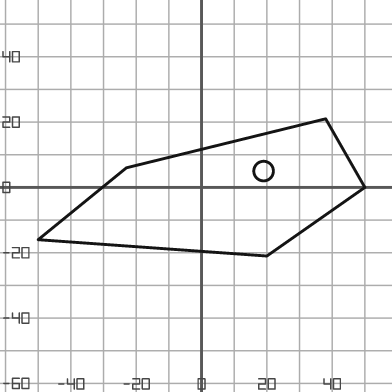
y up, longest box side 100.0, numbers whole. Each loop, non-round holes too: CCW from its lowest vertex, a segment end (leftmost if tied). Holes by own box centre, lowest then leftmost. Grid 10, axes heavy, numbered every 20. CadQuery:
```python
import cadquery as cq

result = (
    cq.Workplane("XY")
    .moveTo(20.0, -21.0)
    .lineTo(50.0, 0.0)
    .lineTo(38.0, 21.0)
    .lineTo(-23.0, 6.0)
    .lineTo(-50.0, -16.0)
    .close()
    .moveTo(19.0, 5.0)
    .circle(3.0)
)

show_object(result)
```